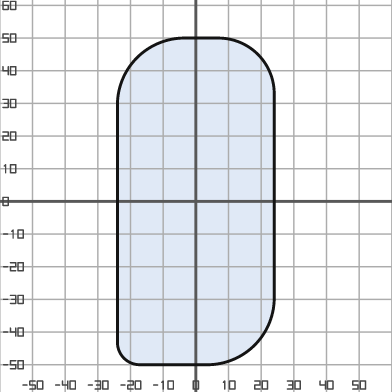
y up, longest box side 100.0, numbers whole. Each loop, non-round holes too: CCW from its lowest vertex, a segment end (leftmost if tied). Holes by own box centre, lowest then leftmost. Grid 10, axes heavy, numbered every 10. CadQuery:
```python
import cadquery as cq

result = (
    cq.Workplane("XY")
    .moveTo(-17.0, -50.0)
    .lineTo(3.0, -50.0)
    .threePointArc((18.0, -44.0), (24.0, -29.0))
    .lineTo(24.0, 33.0)
    .threePointArc((19.0, 45.0), (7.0, 50.0))
    .lineTo(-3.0, 50.0)
    .threePointArc((-18.0, 44.0), (-24.0, 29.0))
    .lineTo(-24.0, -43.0)
    .threePointArc((-22.0, -48.0), (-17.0, -50.0))
    .close()
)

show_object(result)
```